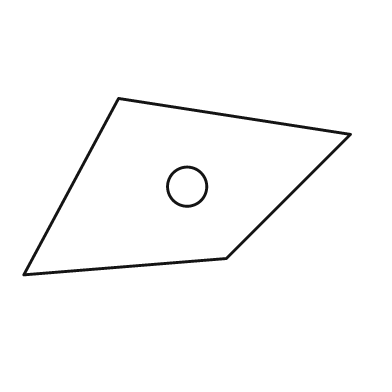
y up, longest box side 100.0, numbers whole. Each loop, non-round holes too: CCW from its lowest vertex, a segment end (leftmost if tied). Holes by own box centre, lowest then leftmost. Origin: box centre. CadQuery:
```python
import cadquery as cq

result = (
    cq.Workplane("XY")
    .moveTo(-50.0, -27.0)
    .lineTo(12.0, -22.0)
    .lineTo(50.0, 16.0)
    .lineTo(-21.0, 27.0)
    .close()
    .moveTo(0.0, 0.0)
    .circle(6.0)
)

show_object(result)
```